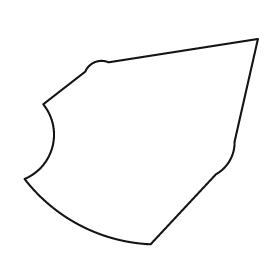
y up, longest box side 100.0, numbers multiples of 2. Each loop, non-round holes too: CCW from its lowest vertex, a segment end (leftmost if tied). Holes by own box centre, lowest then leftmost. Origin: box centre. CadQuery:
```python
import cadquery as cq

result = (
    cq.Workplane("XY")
    .moveTo(4.0, -44.0)
    .lineTo(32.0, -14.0)
    .threePointArc((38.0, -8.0), (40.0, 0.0))
    .lineTo(50.0, 44.0)
    .lineTo(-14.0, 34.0)
    .threePointArc((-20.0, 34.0), (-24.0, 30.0))
    .lineTo(-42.0, 16.0)
    .threePointArc((-38.0, -2.0), (-50.0, -16.0))
    .threePointArc((-26.0, -36.0), (4.0, -44.0))
    .close()
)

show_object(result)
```